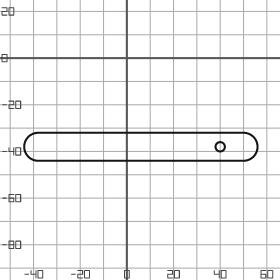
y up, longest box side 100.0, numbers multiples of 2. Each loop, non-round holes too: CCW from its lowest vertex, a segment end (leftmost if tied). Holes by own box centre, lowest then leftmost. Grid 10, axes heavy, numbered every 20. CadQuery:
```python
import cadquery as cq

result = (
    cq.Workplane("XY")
    .moveTo(-38.0, -44.0)
    .lineTo(50.0, -44.0)
    .threePointArc((56.0, -38.0), (50.0, -32.0))
    .lineTo(-38.0, -32.0)
    .threePointArc((-44.0, -38.0), (-38.0, -44.0))
    .close()
    .moveTo(40.0, -38.0)
    .circle(2.0)
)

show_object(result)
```